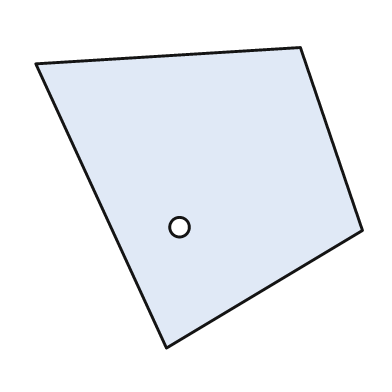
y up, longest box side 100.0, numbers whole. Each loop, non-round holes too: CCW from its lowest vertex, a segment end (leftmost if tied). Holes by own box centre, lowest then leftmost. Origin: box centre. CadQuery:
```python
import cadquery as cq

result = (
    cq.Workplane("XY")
    .moveTo(-10.0, -46.0)
    .lineTo(50.0, -10.0)
    .lineTo(31.0, 46.0)
    .lineTo(-50.0, 41.0)
    .close()
    .moveTo(-6.0, -9.0)
    .circle(3.0)
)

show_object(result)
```